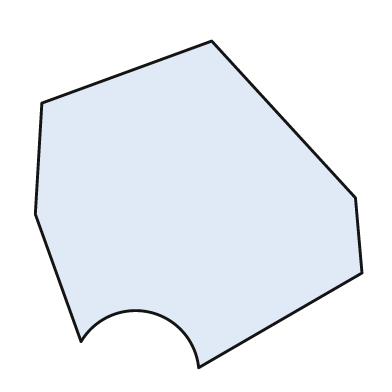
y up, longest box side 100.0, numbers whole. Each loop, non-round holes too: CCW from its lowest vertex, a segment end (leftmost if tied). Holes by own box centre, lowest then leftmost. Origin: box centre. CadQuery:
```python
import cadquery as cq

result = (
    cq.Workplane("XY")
    .moveTo(0.0, -50.0)
    .lineTo(50.0, -21.0)
    .lineTo(48.0, 2.0)
    .lineTo(4.0, 50.0)
    .lineTo(-48.0, 31.0)
    .lineTo(-50.0, -3.0)
    .lineTo(-36.0, -42.0)
    .threePointArc((-15.0, -33.0), (0.0, -50.0))
    .close()
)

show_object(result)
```